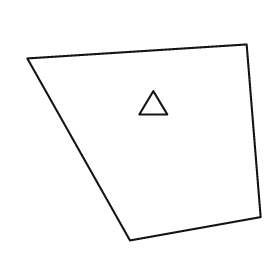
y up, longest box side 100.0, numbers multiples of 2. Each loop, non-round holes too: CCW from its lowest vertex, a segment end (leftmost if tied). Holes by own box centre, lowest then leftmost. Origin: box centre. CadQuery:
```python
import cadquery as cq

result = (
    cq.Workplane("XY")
    .moveTo(-6.0, -42.0)
    .lineTo(50.0, -32.0)
    .lineTo(44.0, 42.0)
    .lineTo(-50.0, 36.0)
    .close()
    .moveTo(-2.0, 12.0)
    .lineTo(10.0, 12.0)
    .lineTo(4.0, 22.0)
    .close()
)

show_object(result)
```